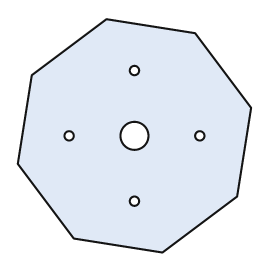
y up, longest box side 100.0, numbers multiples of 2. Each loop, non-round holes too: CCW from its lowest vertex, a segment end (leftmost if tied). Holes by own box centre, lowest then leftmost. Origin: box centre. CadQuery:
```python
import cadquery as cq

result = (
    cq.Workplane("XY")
    .moveTo(12.0, -50.0)
    .lineTo(44.0, -26.0)
    .lineTo(50.0, 12.0)
    .lineTo(26.0, 44.0)
    .lineTo(-12.0, 50.0)
    .lineTo(-44.0, 26.0)
    .lineTo(-50.0, -12.0)
    .lineTo(-26.0, -44.0)
    .close()
    .moveTo(0.0, -28.0)
    .circle(2.0)
    .moveTo(-28.0, 0.0)
    .circle(2.0)
    .moveTo(0.0, 0.0)
    .circle(6.0)
    .moveTo(28.0, 0.0)
    .circle(2.0)
    .moveTo(0.0, 28.0)
    .circle(2.0)
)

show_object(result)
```